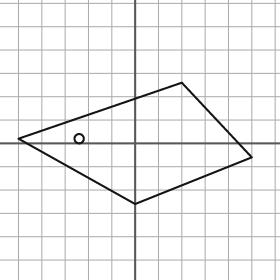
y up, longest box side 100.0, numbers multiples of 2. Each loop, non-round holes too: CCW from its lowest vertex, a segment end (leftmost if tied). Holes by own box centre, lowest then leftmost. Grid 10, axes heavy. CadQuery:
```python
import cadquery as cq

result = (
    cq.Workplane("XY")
    .moveTo(0.0, -26.0)
    .lineTo(50.0, -6.0)
    .lineTo(20.0, 26.0)
    .lineTo(-50.0, 2.0)
    .close()
    .moveTo(-24.0, 2.0)
    .circle(2.0)
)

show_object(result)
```